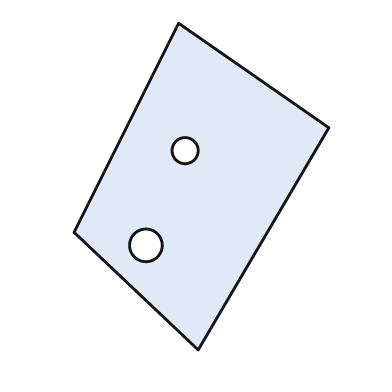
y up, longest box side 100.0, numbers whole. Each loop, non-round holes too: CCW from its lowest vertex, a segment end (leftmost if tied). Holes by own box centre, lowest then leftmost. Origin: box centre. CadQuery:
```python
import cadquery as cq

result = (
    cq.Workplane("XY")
    .moveTo(-1.0, -50.0)
    .lineTo(39.0, 18.0)
    .lineTo(-7.0, 50.0)
    .lineTo(-39.0, -14.0)
    .close()
    .moveTo(-17.0, -18.0)
    .circle(5.0)
    .moveTo(-5.0, 11.0)
    .circle(4.0)
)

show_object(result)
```